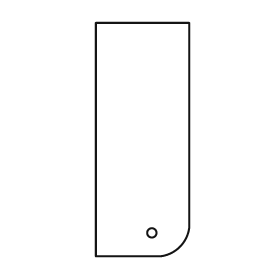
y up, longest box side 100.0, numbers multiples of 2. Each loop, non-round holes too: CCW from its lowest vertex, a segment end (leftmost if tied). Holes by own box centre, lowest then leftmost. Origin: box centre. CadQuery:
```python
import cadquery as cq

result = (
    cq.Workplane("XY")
    .moveTo(-20.0, -50.0)
    .lineTo(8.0, -50.0)
    .threePointArc((16.0, -46.0), (20.0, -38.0))
    .lineTo(20.0, 50.0)
    .lineTo(-20.0, 50.0)
    .close()
    .moveTo(4.0, -40.0)
    .circle(2.0)
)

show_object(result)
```